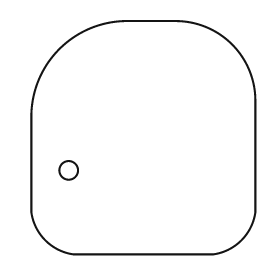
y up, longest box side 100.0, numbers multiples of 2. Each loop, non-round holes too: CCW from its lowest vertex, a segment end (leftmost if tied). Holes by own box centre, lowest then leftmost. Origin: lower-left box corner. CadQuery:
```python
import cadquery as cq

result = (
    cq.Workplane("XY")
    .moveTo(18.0, 0.0)
    .lineTo(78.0, 0.0)
    .threePointArc((90.0, 6.0), (96.0, 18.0))
    .lineTo(96.0, 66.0)
    .threePointArc((86.0, 90.0), (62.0, 100.0))
    .lineTo(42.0, 100.0)
    .threePointArc((12.0, 88.0), (0.0, 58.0))
    .lineTo(0.0, 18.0)
    .threePointArc((6.0, 6.0), (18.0, 0.0))
    .close()
    .moveTo(16.0, 36.0)
    .circle(4.0)
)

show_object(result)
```